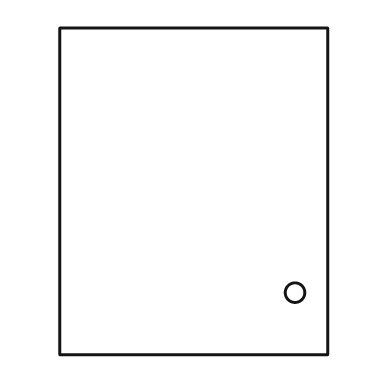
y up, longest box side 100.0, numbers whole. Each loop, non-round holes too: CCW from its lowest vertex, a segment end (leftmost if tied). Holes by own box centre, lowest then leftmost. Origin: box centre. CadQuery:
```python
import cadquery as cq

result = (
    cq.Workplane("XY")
    .moveTo(-41.0, -50.0)
    .lineTo(41.0, -50.0)
    .lineTo(41.0, 50.0)
    .lineTo(-41.0, 50.0)
    .close()
    .moveTo(31.0, -31.0)
    .circle(3.0)
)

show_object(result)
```